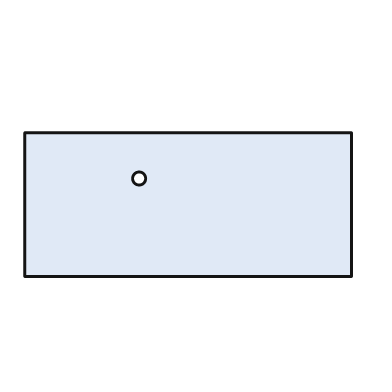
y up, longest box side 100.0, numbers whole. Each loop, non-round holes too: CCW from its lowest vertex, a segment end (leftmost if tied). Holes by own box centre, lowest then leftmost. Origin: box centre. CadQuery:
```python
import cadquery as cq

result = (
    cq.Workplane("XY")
    .moveTo(-50.0, -22.0)
    .lineTo(50.0, -22.0)
    .lineTo(50.0, 22.0)
    .lineTo(-50.0, 22.0)
    .close()
    .moveTo(-15.0, 8.0)
    .circle(2.0)
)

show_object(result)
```